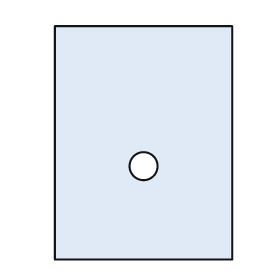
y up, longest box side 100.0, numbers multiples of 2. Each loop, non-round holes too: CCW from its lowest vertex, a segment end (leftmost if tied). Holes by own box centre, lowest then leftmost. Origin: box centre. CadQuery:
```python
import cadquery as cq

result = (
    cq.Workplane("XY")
    .moveTo(-38.0, -50.0)
    .lineTo(38.0, -50.0)
    .lineTo(38.0, 50.0)
    .lineTo(-38.0, 50.0)
    .close()
    .moveTo(0.0, -10.0)
    .circle(6.0)
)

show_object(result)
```